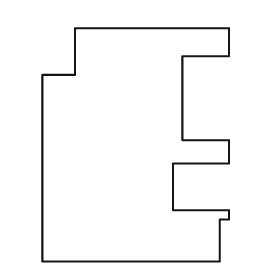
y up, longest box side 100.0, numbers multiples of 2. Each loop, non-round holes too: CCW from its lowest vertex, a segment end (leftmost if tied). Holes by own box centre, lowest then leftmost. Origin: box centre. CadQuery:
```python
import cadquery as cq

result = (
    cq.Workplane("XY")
    .moveTo(-40.0, -50.0)
    .lineTo(36.0, -50.0)
    .lineTo(36.0, -32.0)
    .lineTo(40.0, -32.0)
    .lineTo(40.0, -28.0)
    .lineTo(16.0, -28.0)
    .lineTo(16.0, -8.0)
    .lineTo(40.0, -8.0)
    .lineTo(40.0, 2.0)
    .lineTo(20.0, 2.0)
    .lineTo(20.0, 38.0)
    .lineTo(40.0, 38.0)
    .lineTo(40.0, 50.0)
    .lineTo(-26.0, 50.0)
    .lineTo(-26.0, 30.0)
    .lineTo(-40.0, 30.0)
    .close()
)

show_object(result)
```